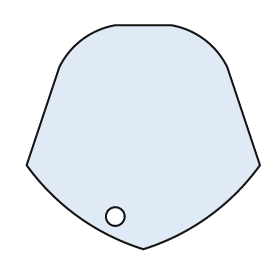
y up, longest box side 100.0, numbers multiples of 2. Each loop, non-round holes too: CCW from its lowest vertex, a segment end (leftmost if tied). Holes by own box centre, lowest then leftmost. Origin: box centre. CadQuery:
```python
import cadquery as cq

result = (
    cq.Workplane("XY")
    .moveTo(0.0, -48.0)
    .threePointArc((28.0, -34.0), (50.0, -12.0))
    .lineTo(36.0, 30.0)
    .threePointArc((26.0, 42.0), (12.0, 48.0))
    .lineTo(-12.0, 48.0)
    .threePointArc((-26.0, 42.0), (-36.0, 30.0))
    .lineTo(-50.0, -12.0)
    .threePointArc((-28.0, -34.0), (0.0, -48.0))
    .close()
    .moveTo(-12.0, -34.0)
    .circle(4.0)
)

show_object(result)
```